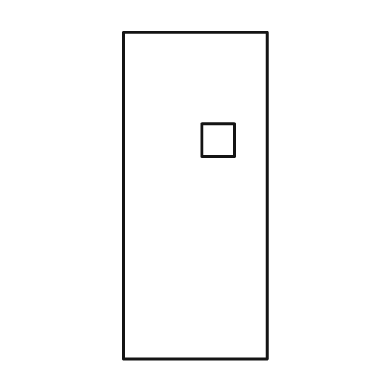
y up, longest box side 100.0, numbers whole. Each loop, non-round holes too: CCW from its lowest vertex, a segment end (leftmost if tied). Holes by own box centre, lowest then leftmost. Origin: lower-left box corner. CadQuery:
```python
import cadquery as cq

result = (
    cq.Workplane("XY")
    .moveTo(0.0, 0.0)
    .lineTo(44.0, 0.0)
    .lineTo(44.0, 100.0)
    .lineTo(0.0, 100.0)
    .close()
    .moveTo(24.0, 62.0)
    .lineTo(34.0, 62.0)
    .lineTo(34.0, 72.0)
    .lineTo(24.0, 72.0)
    .close()
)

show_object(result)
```